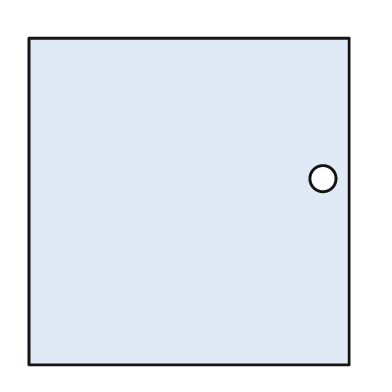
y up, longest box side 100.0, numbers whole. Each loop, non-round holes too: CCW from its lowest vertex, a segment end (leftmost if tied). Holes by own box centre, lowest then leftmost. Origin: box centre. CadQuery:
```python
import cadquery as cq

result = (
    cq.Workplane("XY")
    .moveTo(-49.0, -50.0)
    .lineTo(49.0, -50.0)
    .lineTo(49.0, 50.0)
    .lineTo(-49.0, 50.0)
    .close()
    .moveTo(41.0, 7.0)
    .circle(4.0)
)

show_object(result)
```